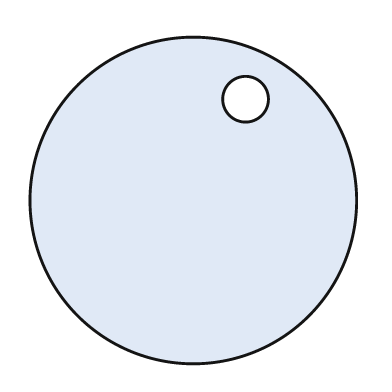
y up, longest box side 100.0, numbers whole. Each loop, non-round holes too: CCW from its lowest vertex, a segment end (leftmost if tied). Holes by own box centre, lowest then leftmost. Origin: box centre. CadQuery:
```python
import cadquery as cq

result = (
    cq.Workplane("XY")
    .moveTo(0.0, 0.0)
    .circle(50.0)
    .moveTo(16.0, 31.0)
    .circle(7.0)
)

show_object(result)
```